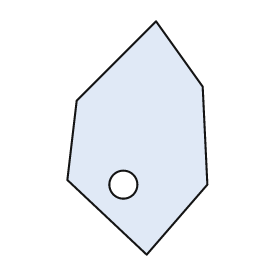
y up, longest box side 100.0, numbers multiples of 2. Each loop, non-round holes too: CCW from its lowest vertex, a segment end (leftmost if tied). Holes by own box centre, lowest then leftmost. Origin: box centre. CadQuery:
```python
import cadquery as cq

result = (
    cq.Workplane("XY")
    .moveTo(4.0, -50.0)
    .lineTo(30.0, -20.0)
    .lineTo(28.0, 22.0)
    .lineTo(8.0, 50.0)
    .lineTo(-26.0, 16.0)
    .lineTo(-30.0, -18.0)
    .close()
    .moveTo(-6.0, -20.0)
    .circle(6.0)
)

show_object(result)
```